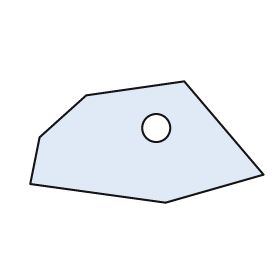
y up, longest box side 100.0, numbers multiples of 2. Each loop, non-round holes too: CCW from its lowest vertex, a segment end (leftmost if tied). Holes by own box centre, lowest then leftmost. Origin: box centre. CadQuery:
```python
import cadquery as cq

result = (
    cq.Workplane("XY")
    .moveTo(8.0, -26.0)
    .lineTo(50.0, -14.0)
    .lineTo(16.0, 26.0)
    .lineTo(-26.0, 20.0)
    .lineTo(-46.0, 2.0)
    .lineTo(-50.0, -18.0)
    .close()
    .moveTo(4.0, 6.0)
    .circle(6.0)
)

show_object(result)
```